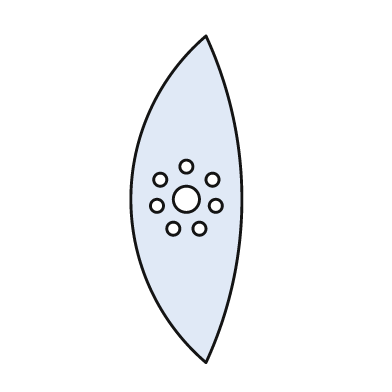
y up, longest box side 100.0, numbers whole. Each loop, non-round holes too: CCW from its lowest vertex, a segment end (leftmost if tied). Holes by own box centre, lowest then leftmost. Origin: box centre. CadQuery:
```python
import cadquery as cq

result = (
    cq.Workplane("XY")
    .moveTo(6.0, -50.0)
    .threePointArc((17.0, 0.0), (6.0, 50.0))
    .threePointArc((-17.0, 0.0), (6.0, -50.0))
    .close()
    .moveTo(-4.0, -9.0)
    .circle(2.0)
    .moveTo(4.0, -9.0)
    .circle(2.0)
    .moveTo(-9.0, -2.0)
    .circle(2.0)
    .moveTo(9.0, -2.0)
    .circle(2.0)
    .moveTo(0.0, 0.0)
    .circle(4.0)
    .moveTo(-8.0, 6.0)
    .circle(2.0)
    .moveTo(8.0, 6.0)
    .circle(2.0)
    .moveTo(0.0, 10.0)
    .circle(2.0)
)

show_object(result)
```